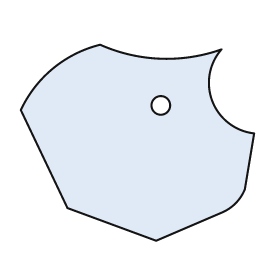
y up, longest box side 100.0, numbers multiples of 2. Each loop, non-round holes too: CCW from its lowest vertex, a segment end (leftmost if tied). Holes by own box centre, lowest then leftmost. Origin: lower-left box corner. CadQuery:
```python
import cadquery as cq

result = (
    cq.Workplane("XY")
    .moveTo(58.0, 0.0)
    .lineTo(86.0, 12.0)
    .threePointArc((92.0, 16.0), (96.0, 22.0))
    .lineTo(100.0, 46.0)
    .threePointArc((82.0, 60.0), (86.0, 82.0))
    .threePointArc((60.0, 78.0), (34.0, 84.0))
    .threePointArc((14.0, 74.0), (0.0, 56.0))
    .lineTo(20.0, 14.0)
    .close()
    .moveTo(60.0, 58.0)
    .circle(4.0)
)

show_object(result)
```